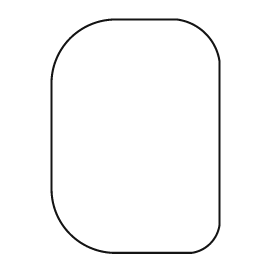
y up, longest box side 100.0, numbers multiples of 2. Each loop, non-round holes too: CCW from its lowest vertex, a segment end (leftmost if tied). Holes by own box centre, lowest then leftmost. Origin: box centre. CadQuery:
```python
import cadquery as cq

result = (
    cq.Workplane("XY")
    .moveTo(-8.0, -50.0)
    .lineTo(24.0, -50.0)
    .threePointArc((32.0, -46.0), (36.0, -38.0))
    .lineTo(36.0, 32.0)
    .threePointArc((30.0, 44.0), (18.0, 50.0))
    .lineTo(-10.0, 50.0)
    .threePointArc((-28.0, 42.0), (-36.0, 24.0))
    .lineTo(-36.0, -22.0)
    .threePointArc((-28.0, -42.0), (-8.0, -50.0))
    .close()
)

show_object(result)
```